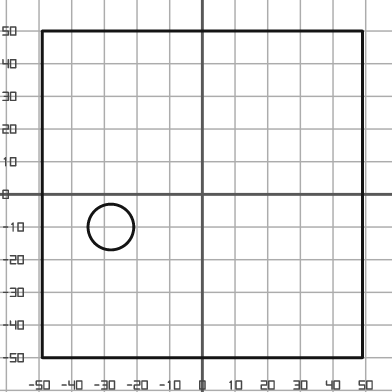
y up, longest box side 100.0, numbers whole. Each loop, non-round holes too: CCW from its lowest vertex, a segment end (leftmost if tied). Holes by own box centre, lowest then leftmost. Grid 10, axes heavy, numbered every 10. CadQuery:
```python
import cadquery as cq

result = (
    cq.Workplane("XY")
    .moveTo(-49.0, -50.0)
    .lineTo(49.0, -50.0)
    .lineTo(49.0, 50.0)
    .lineTo(-49.0, 50.0)
    .close()
    .moveTo(-28.0, -10.0)
    .circle(7.0)
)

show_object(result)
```